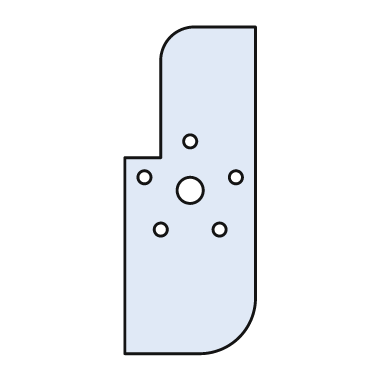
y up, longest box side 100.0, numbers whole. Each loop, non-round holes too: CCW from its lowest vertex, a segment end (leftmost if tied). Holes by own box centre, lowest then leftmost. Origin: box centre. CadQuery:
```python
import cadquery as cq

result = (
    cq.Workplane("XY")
    .moveTo(-20.0, -50.0)
    .lineTo(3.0, -50.0)
    .threePointArc((15.0, -45.0), (20.0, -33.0))
    .lineTo(20.0, 50.0)
    .lineTo(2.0, 50.0)
    .threePointArc((-6.0, 47.0), (-9.0, 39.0))
    .lineTo(-9.0, 10.0)
    .lineTo(-20.0, 10.0)
    .close()
    .moveTo(-9.0, -12.0)
    .circle(2.0)
    .moveTo(9.0, -12.0)
    .circle(2.0)
    .moveTo(0.0, 0.0)
    .circle(4.0)
    .moveTo(-14.0, 4.0)
    .circle(2.0)
    .moveTo(14.0, 4.0)
    .circle(2.0)
    .moveTo(0.0, 15.0)
    .circle(2.0)
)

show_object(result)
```